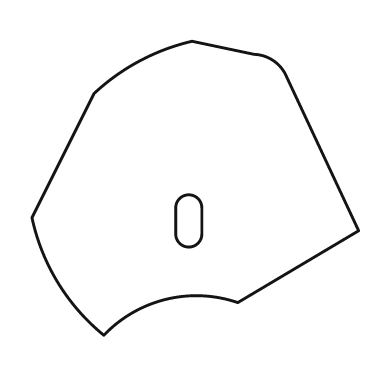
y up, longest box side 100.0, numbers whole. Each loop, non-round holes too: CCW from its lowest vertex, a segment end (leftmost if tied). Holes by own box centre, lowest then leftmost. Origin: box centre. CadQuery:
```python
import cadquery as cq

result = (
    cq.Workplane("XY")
    .moveTo(-28.0, -45.0)
    .threePointArc((-9.0, -34.0), (13.0, -35.0))
    .lineTo(50.0, -13.0)
    .lineTo(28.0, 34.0)
    .threePointArc((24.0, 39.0), (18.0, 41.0))
    .lineTo(-1.0, 45.0)
    .threePointArc((-17.0, 39.0), (-31.0, 29.0))
    .lineTo(-50.0, -9.0)
    .threePointArc((-42.0, -29.0), (-28.0, -45.0))
    .close()
    .moveTo(-6.0, -14.0)
    .threePointArc((-2.0, -18.0), (2.0, -14.0))
    .lineTo(2.0, -6.0)
    .threePointArc((-2.0, -2.0), (-6.0, -6.0))
    .close()
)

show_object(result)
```